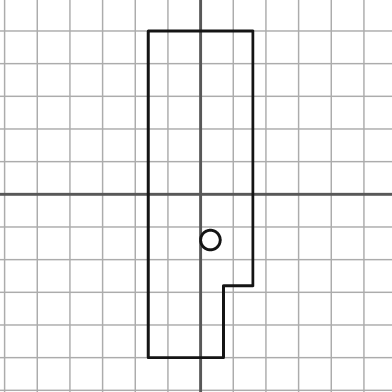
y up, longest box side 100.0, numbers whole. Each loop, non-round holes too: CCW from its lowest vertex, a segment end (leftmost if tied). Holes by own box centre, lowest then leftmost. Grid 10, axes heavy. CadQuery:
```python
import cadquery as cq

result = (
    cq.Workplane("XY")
    .moveTo(-16.0, -50.0)
    .lineTo(7.0, -50.0)
    .lineTo(7.0, -28.0)
    .lineTo(16.0, -28.0)
    .lineTo(16.0, 50.0)
    .lineTo(-16.0, 50.0)
    .close()
    .moveTo(3.0, -14.0)
    .circle(3.0)
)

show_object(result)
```